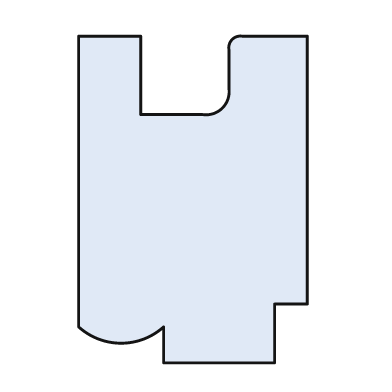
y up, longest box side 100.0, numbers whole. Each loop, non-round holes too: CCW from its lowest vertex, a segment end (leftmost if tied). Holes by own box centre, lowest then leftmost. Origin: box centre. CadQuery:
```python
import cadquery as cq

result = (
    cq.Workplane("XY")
    .moveTo(-9.0, -50.0)
    .lineTo(25.0, -50.0)
    .lineTo(25.0, -32.0)
    .lineTo(35.0, -32.0)
    .lineTo(35.0, 50.0)
    .lineTo(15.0, 50.0)
    .threePointArc((12.0, 49.0), (11.0, 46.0))
    .lineTo(11.0, 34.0)
    .threePointArc((9.0, 28.0), (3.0, 26.0))
    .lineTo(-16.0, 26.0)
    .lineTo(-16.0, 50.0)
    .lineTo(-35.0, 50.0)
    .lineTo(-35.0, -39.0)
    .threePointArc((-22.0, -44.0), (-9.0, -39.0))
    .close()
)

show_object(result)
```